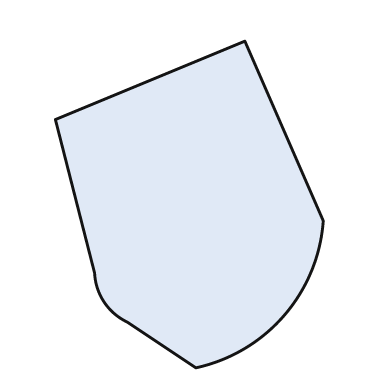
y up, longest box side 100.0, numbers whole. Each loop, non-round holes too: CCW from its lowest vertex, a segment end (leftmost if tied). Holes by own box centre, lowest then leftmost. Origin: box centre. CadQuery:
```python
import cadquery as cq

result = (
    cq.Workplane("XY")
    .moveTo(2.0, -50.0)
    .threePointArc((29.0, -34.0), (41.0, -5.0))
    .lineTo(17.0, 50.0)
    .lineTo(-41.0, 26.0)
    .lineTo(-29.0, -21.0)
    .threePointArc((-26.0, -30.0), (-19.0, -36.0))
    .close()
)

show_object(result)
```